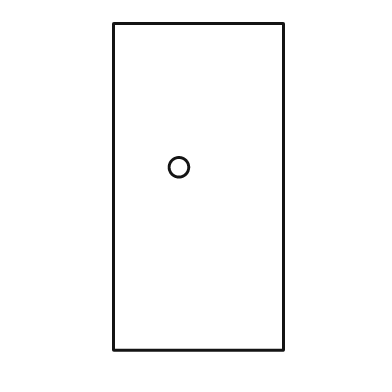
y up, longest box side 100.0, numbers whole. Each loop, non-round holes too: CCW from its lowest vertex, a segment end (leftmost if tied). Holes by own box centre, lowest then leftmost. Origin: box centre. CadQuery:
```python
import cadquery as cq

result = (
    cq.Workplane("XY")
    .moveTo(-26.0, -50.0)
    .lineTo(26.0, -50.0)
    .lineTo(26.0, 50.0)
    .lineTo(-26.0, 50.0)
    .close()
    .moveTo(-6.0, 6.0)
    .circle(3.0)
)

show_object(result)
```